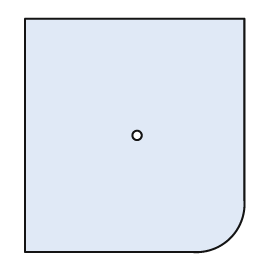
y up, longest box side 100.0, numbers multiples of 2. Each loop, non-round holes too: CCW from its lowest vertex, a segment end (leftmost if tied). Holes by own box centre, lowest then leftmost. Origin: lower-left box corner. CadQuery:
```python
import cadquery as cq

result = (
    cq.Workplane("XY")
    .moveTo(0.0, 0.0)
    .lineTo(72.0, 0.0)
    .threePointArc((88.0, 6.0), (94.0, 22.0))
    .lineTo(94.0, 100.0)
    .lineTo(0.0, 100.0)
    .close()
    .moveTo(48.0, 50.0)
    .circle(2.0)
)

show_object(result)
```